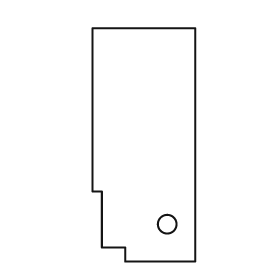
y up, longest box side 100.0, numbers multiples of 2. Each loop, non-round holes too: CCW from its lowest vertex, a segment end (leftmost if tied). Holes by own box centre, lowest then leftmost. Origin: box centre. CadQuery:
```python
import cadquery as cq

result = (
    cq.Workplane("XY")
    .moveTo(-8.0, -50.0)
    .lineTo(22.0, -50.0)
    .lineTo(22.0, 50.0)
    .lineTo(-22.0, 50.0)
    .lineTo(-22.0, -20.0)
    .lineTo(-18.0, -20.0)
    .lineTo(-18.0, -44.0)
    .lineTo(-8.0, -44.0)
    .close()
    .moveTo(10.0, -34.0)
    .circle(4.0)
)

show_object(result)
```